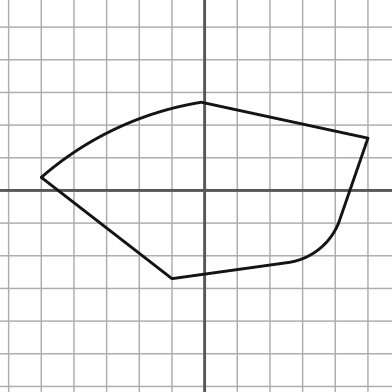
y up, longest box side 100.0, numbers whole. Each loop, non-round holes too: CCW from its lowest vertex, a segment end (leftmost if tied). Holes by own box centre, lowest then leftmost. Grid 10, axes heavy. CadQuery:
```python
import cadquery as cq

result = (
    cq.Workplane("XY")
    .moveTo(-10.0, -27.0)
    .lineTo(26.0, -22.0)
    .threePointArc((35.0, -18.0), (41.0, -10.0))
    .lineTo(50.0, 16.0)
    .lineTo(-1.0, 27.0)
    .threePointArc((-27.0, 19.0), (-50.0, 4.0))
    .close()
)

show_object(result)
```